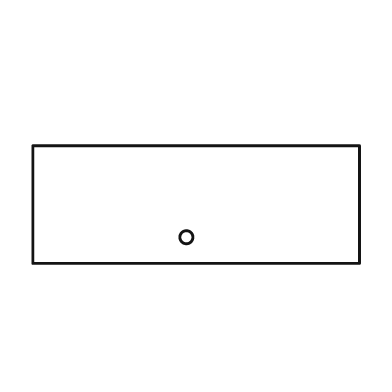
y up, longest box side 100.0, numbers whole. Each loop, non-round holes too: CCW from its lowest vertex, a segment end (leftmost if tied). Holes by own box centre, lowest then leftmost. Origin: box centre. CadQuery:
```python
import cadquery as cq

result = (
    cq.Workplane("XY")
    .moveTo(-50.0, -18.0)
    .lineTo(50.0, -18.0)
    .lineTo(50.0, 18.0)
    .lineTo(-50.0, 18.0)
    .close()
    .moveTo(-3.0, -10.0)
    .circle(2.0)
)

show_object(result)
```